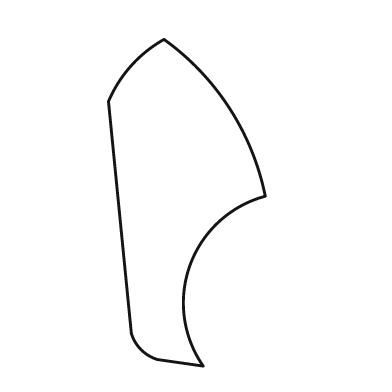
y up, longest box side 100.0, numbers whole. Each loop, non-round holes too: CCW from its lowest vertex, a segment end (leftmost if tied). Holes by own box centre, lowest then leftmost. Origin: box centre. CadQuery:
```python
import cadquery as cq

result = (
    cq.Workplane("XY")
    .moveTo(5.0, -50.0)
    .threePointArc((1.0, -19.0), (24.0, 2.0))
    .threePointArc((13.0, 29.0), (-7.0, 50.0))
    .threePointArc((-17.0, 42.0), (-24.0, 31.0))
    .lineTo(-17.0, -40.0)
    .threePointArc((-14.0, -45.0), (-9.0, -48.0))
    .close()
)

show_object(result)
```